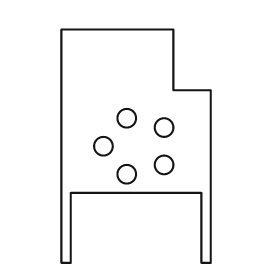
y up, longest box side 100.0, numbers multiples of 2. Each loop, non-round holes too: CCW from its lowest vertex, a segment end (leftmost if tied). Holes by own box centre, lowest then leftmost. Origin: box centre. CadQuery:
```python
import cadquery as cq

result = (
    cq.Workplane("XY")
    .moveTo(-32.0, -50.0)
    .lineTo(-28.0, -50.0)
    .lineTo(-28.0, -20.0)
    .lineTo(28.0, -20.0)
    .lineTo(28.0, -50.0)
    .lineTo(32.0, -50.0)
    .lineTo(32.0, 24.0)
    .lineTo(16.0, 24.0)
    .lineTo(16.0, 50.0)
    .lineTo(-32.0, 50.0)
    .close()
    .moveTo(-4.0, -12.0)
    .circle(4.0)
    .moveTo(12.0, -8.0)
    .circle(4.0)
    .moveTo(-14.0, 0.0)
    .circle(4.0)
    .moveTo(12.0, 8.0)
    .circle(4.0)
    .moveTo(-4.0, 12.0)
    .circle(4.0)
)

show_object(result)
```